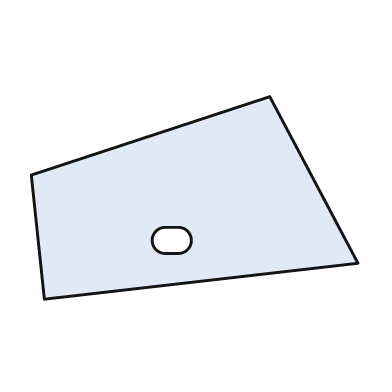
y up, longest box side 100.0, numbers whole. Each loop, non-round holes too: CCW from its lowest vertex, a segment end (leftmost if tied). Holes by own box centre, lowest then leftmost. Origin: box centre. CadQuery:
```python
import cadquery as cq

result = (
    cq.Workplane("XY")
    .moveTo(-46.0, -31.0)
    .lineTo(50.0, -20.0)
    .lineTo(23.0, 31.0)
    .lineTo(-50.0, 7.0)
    .close()
    .moveTo(-9.0, -17.0)
    .lineTo(-5.0, -17.0)
    .threePointArc((-1.0, -13.0), (-5.0, -9.0))
    .lineTo(-9.0, -9.0)
    .threePointArc((-13.0, -13.0), (-9.0, -17.0))
    .close()
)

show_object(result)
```